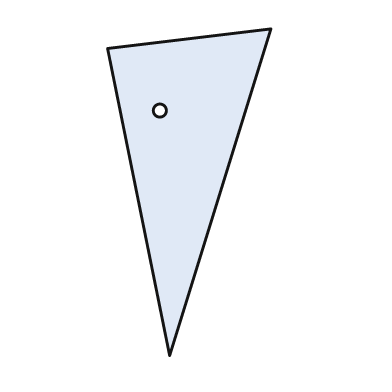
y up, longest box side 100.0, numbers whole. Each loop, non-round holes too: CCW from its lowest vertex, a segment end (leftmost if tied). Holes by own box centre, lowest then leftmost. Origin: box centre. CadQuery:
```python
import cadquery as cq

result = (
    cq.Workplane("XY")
    .moveTo(-6.0, -50.0)
    .lineTo(25.0, 50.0)
    .lineTo(-25.0, 44.0)
    .close()
    .moveTo(-9.0, 25.0)
    .circle(2.0)
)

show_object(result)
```